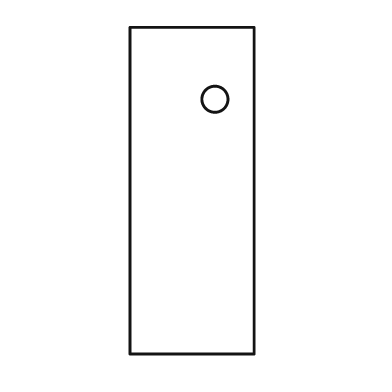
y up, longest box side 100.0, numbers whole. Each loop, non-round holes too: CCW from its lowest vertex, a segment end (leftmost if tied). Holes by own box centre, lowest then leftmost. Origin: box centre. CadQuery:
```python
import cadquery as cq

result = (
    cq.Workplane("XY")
    .moveTo(-19.0, -50.0)
    .lineTo(19.0, -50.0)
    .lineTo(19.0, 50.0)
    .lineTo(-19.0, 50.0)
    .close()
    .moveTo(7.0, 28.0)
    .circle(4.0)
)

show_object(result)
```